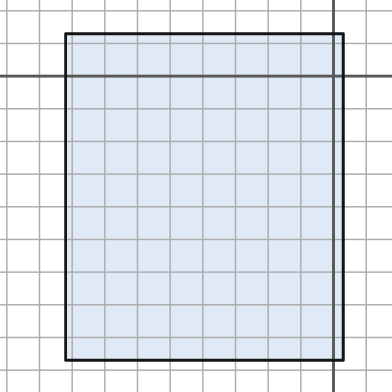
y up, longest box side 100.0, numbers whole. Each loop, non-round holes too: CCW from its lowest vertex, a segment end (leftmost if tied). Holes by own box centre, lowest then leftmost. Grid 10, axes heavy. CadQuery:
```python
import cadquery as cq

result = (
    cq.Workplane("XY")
    .moveTo(-82.0, -87.0)
    .lineTo(3.0, -87.0)
    .lineTo(3.0, 13.0)
    .lineTo(-82.0, 13.0)
    .close()
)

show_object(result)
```